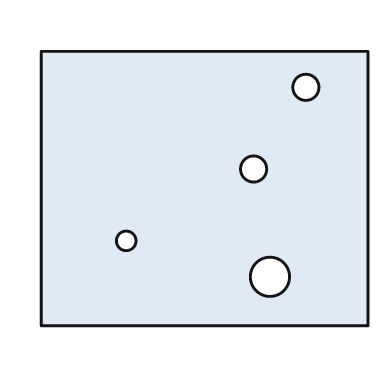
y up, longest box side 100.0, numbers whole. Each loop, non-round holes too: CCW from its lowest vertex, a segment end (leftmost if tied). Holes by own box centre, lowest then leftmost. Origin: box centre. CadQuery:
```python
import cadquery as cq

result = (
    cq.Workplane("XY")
    .moveTo(-50.0, -42.0)
    .lineTo(50.0, -42.0)
    .lineTo(50.0, 42.0)
    .lineTo(-50.0, 42.0)
    .close()
    .moveTo(20.0, -27.0)
    .circle(6.0)
    .moveTo(-24.0, -16.0)
    .circle(3.0)
    .moveTo(15.0, 6.0)
    .circle(4.0)
    .moveTo(31.0, 31.0)
    .circle(4.0)
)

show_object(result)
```